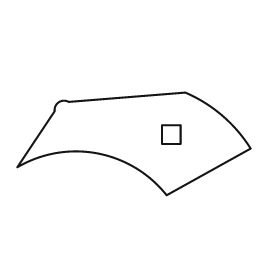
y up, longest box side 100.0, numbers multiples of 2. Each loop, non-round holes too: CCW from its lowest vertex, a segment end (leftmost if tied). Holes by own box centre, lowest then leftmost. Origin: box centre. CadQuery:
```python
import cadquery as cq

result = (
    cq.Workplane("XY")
    .moveTo(14.0, -22.0)
    .lineTo(50.0, -2.0)
    .threePointArc((38.0, 12.0), (22.0, 22.0))
    .lineTo(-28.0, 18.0)
    .threePointArc((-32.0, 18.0), (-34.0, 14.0))
    .lineTo(-50.0, -10.0)
    .threePointArc((-16.0, -4.0), (14.0, -22.0))
    .close()
    .moveTo(12.0, 0.0)
    .lineTo(20.0, 0.0)
    .lineTo(20.0, 8.0)
    .lineTo(12.0, 8.0)
    .close()
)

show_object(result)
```